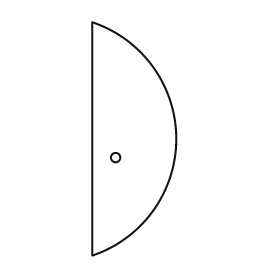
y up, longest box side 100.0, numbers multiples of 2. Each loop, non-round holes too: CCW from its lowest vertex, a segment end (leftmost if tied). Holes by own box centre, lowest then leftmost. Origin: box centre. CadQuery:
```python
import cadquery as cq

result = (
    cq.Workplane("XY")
    .moveTo(-18.0, -50.0)
    .threePointArc((18.0, 0.0), (-18.0, 50.0))
    .close()
    .moveTo(-8.0, -8.0)
    .circle(2.0)
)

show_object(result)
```